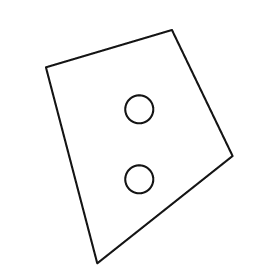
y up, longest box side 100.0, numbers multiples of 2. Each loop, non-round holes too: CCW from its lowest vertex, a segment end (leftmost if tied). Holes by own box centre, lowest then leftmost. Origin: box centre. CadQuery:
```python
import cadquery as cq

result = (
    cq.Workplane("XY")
    .moveTo(-18.0, -50.0)
    .lineTo(40.0, -4.0)
    .lineTo(14.0, 50.0)
    .lineTo(-40.0, 34.0)
    .close()
    .moveTo(0.0, -14.0)
    .circle(6.0)
    .moveTo(0.0, 16.0)
    .circle(6.0)
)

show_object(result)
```